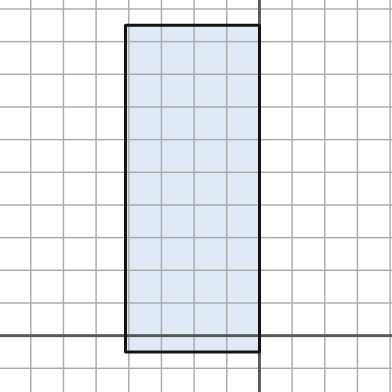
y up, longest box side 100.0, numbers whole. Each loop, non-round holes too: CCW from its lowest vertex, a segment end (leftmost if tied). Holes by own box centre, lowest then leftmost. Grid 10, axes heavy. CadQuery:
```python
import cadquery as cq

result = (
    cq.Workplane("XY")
    .moveTo(-41.0, -5.0)
    .lineTo(0.0, -5.0)
    .lineTo(0.0, 95.0)
    .lineTo(-41.0, 95.0)
    .close()
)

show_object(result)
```